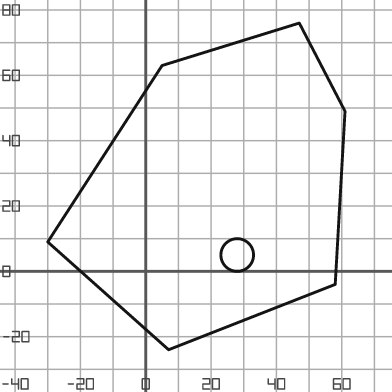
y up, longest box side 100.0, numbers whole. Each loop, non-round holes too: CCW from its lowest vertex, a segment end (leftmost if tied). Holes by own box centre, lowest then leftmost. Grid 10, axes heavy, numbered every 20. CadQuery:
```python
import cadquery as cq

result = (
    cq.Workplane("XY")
    .moveTo(7.0, -24.0)
    .lineTo(58.0, -4.0)
    .lineTo(61.0, 49.0)
    .lineTo(47.0, 76.0)
    .lineTo(5.0, 63.0)
    .lineTo(-30.0, 9.0)
    .close()
    .moveTo(28.0, 5.0)
    .circle(5.0)
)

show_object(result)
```